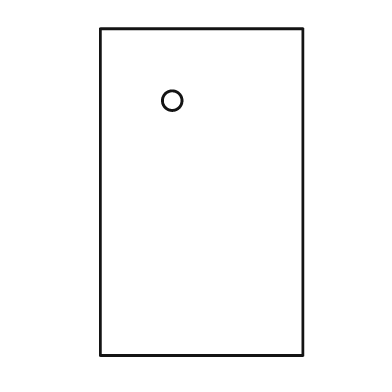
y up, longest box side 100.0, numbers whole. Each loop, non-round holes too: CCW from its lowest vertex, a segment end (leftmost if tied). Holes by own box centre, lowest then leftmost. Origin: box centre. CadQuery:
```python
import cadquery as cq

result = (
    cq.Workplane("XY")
    .moveTo(-31.0, -50.0)
    .lineTo(31.0, -50.0)
    .lineTo(31.0, 50.0)
    .lineTo(-31.0, 50.0)
    .close()
    .moveTo(-9.0, 28.0)
    .circle(3.0)
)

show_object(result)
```